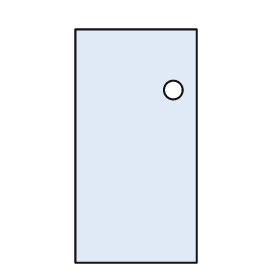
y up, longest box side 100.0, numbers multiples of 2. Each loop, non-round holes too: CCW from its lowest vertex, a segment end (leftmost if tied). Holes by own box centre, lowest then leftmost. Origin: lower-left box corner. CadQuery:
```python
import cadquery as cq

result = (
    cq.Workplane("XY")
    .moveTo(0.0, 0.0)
    .lineTo(52.0, 0.0)
    .lineTo(52.0, 100.0)
    .lineTo(0.0, 100.0)
    .close()
    .moveTo(42.0, 74.0)
    .circle(4.0)
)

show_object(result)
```